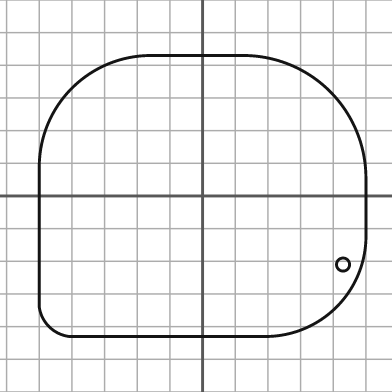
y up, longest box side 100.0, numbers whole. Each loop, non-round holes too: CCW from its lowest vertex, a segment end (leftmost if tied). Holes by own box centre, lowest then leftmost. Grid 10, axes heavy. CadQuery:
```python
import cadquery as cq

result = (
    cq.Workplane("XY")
    .moveTo(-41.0, -43.0)
    .lineTo(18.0, -43.0)
    .threePointArc((41.0, -34.0), (50.0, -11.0))
    .lineTo(50.0, 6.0)
    .threePointArc((39.0, 32.0), (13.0, 43.0))
    .lineTo(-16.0, 43.0)
    .threePointArc((-40.0, 33.0), (-50.0, 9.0))
    .lineTo(-50.0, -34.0)
    .threePointArc((-47.0, -40.0), (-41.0, -43.0))
    .close()
    .moveTo(43.0, -21.0)
    .circle(2.0)
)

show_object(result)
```